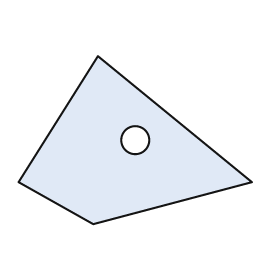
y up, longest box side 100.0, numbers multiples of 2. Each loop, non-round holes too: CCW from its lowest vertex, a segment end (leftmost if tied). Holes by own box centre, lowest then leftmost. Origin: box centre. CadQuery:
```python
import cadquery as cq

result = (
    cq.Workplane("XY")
    .moveTo(-18.0, -36.0)
    .lineTo(50.0, -18.0)
    .lineTo(-16.0, 36.0)
    .lineTo(-50.0, -18.0)
    .close()
    .moveTo(0.0, 0.0)
    .circle(6.0)
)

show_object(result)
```